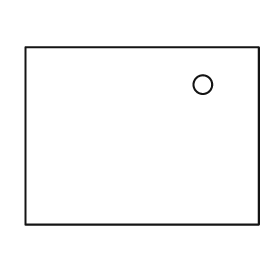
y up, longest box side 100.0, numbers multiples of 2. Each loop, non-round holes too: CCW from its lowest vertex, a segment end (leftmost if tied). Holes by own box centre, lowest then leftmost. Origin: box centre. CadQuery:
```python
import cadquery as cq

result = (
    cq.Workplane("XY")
    .moveTo(-50.0, -38.0)
    .lineTo(50.0, -38.0)
    .lineTo(50.0, 38.0)
    .lineTo(-50.0, 38.0)
    .close()
    .moveTo(26.0, 22.0)
    .circle(4.0)
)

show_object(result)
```